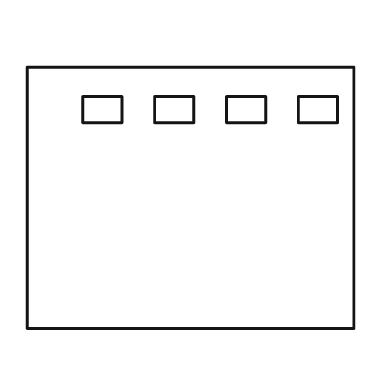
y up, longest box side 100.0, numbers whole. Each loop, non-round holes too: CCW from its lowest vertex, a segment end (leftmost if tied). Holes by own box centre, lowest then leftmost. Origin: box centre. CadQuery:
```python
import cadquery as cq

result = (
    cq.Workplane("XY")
    .moveTo(-50.0, -40.0)
    .lineTo(50.0, -40.0)
    .lineTo(50.0, 40.0)
    .lineTo(-50.0, 40.0)
    .close()
    .moveTo(-33.0, 23.0)
    .lineTo(-21.0, 23.0)
    .lineTo(-21.0, 31.0)
    .lineTo(-33.0, 31.0)
    .close()
    .moveTo(-11.0, 23.0)
    .lineTo(1.0, 23.0)
    .lineTo(1.0, 31.0)
    .lineTo(-11.0, 31.0)
    .close()
    .moveTo(11.0, 23.0)
    .lineTo(23.0, 23.0)
    .lineTo(23.0, 31.0)
    .lineTo(11.0, 31.0)
    .close()
    .moveTo(33.0, 23.0)
    .lineTo(45.0, 23.0)
    .lineTo(45.0, 31.0)
    .lineTo(33.0, 31.0)
    .close()
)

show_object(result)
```